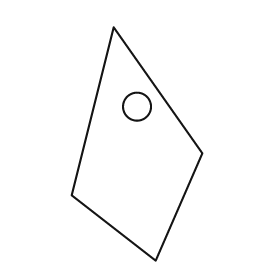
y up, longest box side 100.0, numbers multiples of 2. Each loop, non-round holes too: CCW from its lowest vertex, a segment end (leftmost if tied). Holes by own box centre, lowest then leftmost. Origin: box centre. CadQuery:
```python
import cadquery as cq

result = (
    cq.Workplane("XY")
    .moveTo(8.0, -50.0)
    .lineTo(28.0, -4.0)
    .lineTo(-10.0, 50.0)
    .lineTo(-28.0, -22.0)
    .close()
    .moveTo(0.0, 16.0)
    .circle(6.0)
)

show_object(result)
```